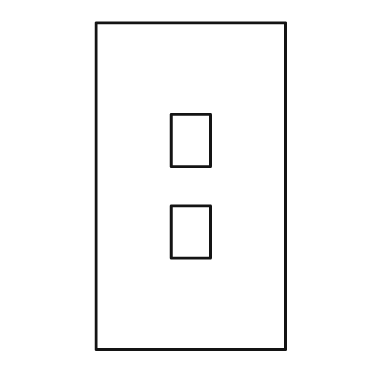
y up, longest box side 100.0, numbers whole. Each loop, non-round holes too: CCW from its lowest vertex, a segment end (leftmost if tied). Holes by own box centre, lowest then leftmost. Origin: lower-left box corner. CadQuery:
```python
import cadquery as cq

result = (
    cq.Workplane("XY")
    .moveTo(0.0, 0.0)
    .lineTo(58.0, 0.0)
    .lineTo(58.0, 100.0)
    .lineTo(0.0, 100.0)
    .close()
    .moveTo(23.0, 28.0)
    .lineTo(35.0, 28.0)
    .lineTo(35.0, 44.0)
    .lineTo(23.0, 44.0)
    .close()
    .moveTo(23.0, 56.0)
    .lineTo(35.0, 56.0)
    .lineTo(35.0, 72.0)
    .lineTo(23.0, 72.0)
    .close()
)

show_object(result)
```